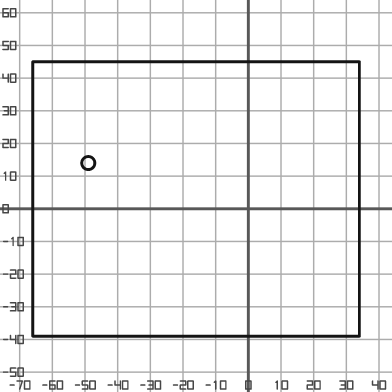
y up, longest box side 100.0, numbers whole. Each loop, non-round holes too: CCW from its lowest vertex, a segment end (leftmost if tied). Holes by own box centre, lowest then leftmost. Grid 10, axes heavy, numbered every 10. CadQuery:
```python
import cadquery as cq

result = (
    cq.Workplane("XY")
    .moveTo(-66.0, -39.0)
    .lineTo(34.0, -39.0)
    .lineTo(34.0, 45.0)
    .lineTo(-66.0, 45.0)
    .close()
    .moveTo(-49.0, 14.0)
    .circle(2.0)
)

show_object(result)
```